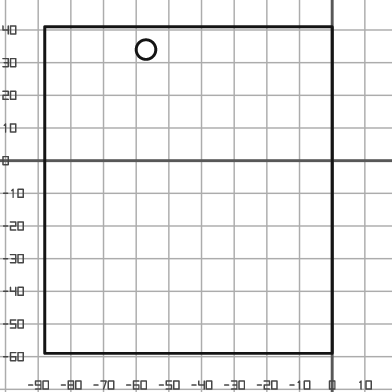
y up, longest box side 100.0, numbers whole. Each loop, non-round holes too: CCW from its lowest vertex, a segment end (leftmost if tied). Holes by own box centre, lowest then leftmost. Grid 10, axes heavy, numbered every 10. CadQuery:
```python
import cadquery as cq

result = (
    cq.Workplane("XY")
    .moveTo(-88.0, -59.0)
    .lineTo(0.0, -59.0)
    .lineTo(0.0, 41.0)
    .lineTo(-88.0, 41.0)
    .close()
    .moveTo(-57.0, 34.0)
    .circle(3.0)
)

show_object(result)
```